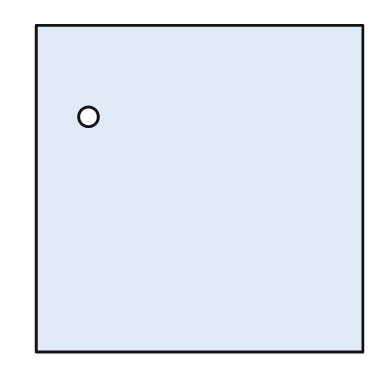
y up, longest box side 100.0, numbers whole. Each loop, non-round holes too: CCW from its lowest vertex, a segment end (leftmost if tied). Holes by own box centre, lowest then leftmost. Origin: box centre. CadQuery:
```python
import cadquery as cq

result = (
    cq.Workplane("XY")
    .moveTo(-50.0, -50.0)
    .lineTo(50.0, -50.0)
    .lineTo(50.0, 50.0)
    .lineTo(-50.0, 50.0)
    .close()
    .moveTo(-34.0, 22.0)
    .circle(3.0)
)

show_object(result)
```